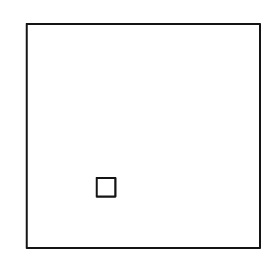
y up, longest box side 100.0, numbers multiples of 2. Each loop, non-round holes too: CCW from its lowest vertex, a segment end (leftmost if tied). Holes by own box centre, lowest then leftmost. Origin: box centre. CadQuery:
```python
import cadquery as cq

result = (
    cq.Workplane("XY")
    .moveTo(-50.0, -48.0)
    .lineTo(50.0, -48.0)
    .lineTo(50.0, 48.0)
    .lineTo(-50.0, 48.0)
    .close()
    .moveTo(-20.0, -26.0)
    .lineTo(-12.0, -26.0)
    .lineTo(-12.0, -18.0)
    .lineTo(-20.0, -18.0)
    .close()
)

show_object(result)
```